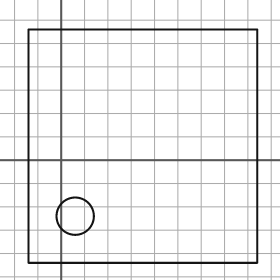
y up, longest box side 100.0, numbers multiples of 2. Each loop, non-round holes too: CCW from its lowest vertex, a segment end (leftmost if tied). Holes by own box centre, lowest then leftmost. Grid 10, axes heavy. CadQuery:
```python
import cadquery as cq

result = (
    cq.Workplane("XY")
    .moveTo(-14.0, -44.0)
    .lineTo(84.0, -44.0)
    .lineTo(84.0, 56.0)
    .lineTo(-14.0, 56.0)
    .close()
    .moveTo(6.0, -24.0)
    .circle(8.0)
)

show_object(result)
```